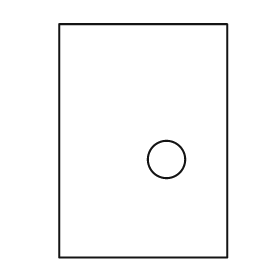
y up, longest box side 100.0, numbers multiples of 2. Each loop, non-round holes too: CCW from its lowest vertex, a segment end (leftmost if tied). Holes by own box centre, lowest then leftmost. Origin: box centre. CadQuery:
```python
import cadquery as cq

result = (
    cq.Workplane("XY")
    .moveTo(-36.0, -50.0)
    .lineTo(36.0, -50.0)
    .lineTo(36.0, 50.0)
    .lineTo(-36.0, 50.0)
    .close()
    .moveTo(10.0, -8.0)
    .circle(8.0)
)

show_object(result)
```